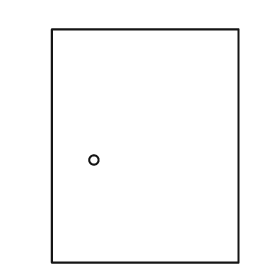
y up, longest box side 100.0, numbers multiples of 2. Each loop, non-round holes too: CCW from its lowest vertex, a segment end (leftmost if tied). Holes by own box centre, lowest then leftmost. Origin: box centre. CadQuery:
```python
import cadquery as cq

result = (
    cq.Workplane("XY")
    .moveTo(-40.0, -50.0)
    .lineTo(40.0, -50.0)
    .lineTo(40.0, 50.0)
    .lineTo(-40.0, 50.0)
    .close()
    .moveTo(-22.0, -6.0)
    .circle(2.0)
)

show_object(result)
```